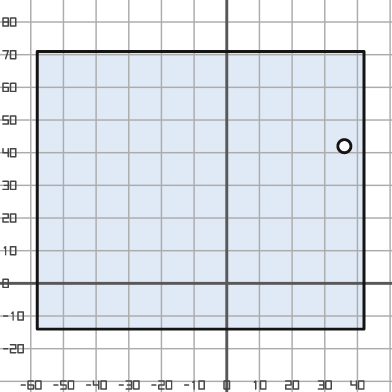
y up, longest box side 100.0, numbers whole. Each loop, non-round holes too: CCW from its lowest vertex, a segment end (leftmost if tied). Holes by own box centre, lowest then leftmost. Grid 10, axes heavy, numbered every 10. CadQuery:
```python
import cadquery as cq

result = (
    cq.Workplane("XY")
    .moveTo(-58.0, -14.0)
    .lineTo(42.0, -14.0)
    .lineTo(42.0, 71.0)
    .lineTo(-58.0, 71.0)
    .close()
    .moveTo(36.0, 42.0)
    .circle(2.0)
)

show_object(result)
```